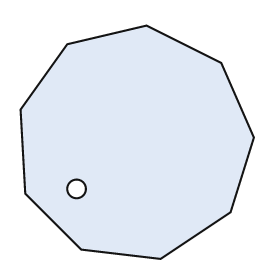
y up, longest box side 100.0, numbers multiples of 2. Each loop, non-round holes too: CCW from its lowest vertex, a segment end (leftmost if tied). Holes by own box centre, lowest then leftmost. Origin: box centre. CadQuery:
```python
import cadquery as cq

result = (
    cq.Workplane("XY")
    .moveTo(10.0, -50.0)
    .lineTo(40.0, -30.0)
    .lineTo(50.0, 2.0)
    .lineTo(36.0, 34.0)
    .lineTo(4.0, 50.0)
    .lineTo(-30.0, 42.0)
    .lineTo(-50.0, 14.0)
    .lineTo(-48.0, -22.0)
    .lineTo(-24.0, -46.0)
    .close()
    .moveTo(-26.0, -20.0)
    .circle(4.0)
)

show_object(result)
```